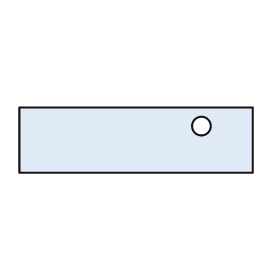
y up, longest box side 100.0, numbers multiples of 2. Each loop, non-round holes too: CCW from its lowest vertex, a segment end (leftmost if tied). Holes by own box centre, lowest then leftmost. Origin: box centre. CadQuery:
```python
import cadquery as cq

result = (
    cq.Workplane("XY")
    .moveTo(-50.0, -14.0)
    .lineTo(50.0, -14.0)
    .lineTo(50.0, 14.0)
    .lineTo(-50.0, 14.0)
    .close()
    .moveTo(28.0, 6.0)
    .circle(4.0)
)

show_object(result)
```